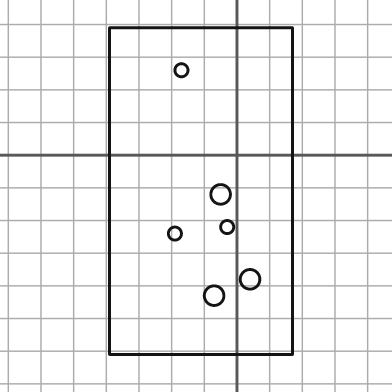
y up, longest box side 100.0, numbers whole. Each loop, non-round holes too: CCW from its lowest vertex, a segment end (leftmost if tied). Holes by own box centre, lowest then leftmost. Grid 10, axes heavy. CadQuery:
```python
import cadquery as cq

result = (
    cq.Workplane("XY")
    .moveTo(-39.0, -61.0)
    .lineTo(17.0, -61.0)
    .lineTo(17.0, 39.0)
    .lineTo(-39.0, 39.0)
    .close()
    .moveTo(-7.0, -43.0)
    .circle(3.0)
    .moveTo(4.0, -38.0)
    .circle(3.0)
    .moveTo(-19.0, -24.0)
    .circle(2.0)
    .moveTo(-3.0, -22.0)
    .circle(2.0)
    .moveTo(-5.0, -12.0)
    .circle(3.0)
    .moveTo(-17.0, 26.0)
    .circle(2.0)
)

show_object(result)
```